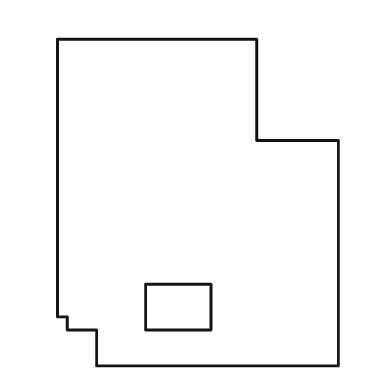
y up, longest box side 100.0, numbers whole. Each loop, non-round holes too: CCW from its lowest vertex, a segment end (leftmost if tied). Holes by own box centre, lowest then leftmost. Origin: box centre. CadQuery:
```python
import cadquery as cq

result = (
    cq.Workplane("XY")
    .moveTo(-31.0, -50.0)
    .lineTo(43.0, -50.0)
    .lineTo(43.0, 19.0)
    .lineTo(18.0, 19.0)
    .lineTo(18.0, 50.0)
    .lineTo(-43.0, 50.0)
    .lineTo(-43.0, -35.0)
    .lineTo(-40.0, -35.0)
    .lineTo(-40.0, -39.0)
    .lineTo(-31.0, -39.0)
    .close()
    .moveTo(-16.0, -39.0)
    .lineTo(4.0, -39.0)
    .lineTo(4.0, -25.0)
    .lineTo(-16.0, -25.0)
    .close()
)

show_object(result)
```